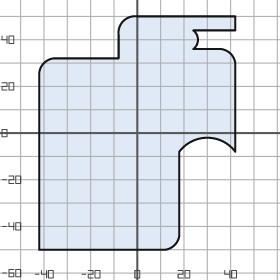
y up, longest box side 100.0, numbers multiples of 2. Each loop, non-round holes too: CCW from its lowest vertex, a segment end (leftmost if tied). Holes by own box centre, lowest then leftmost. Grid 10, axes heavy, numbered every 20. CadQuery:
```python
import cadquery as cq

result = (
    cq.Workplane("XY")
    .moveTo(-42.0, -50.0)
    .lineTo(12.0, -50.0)
    .threePointArc((16.0, -48.0), (18.0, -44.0))
    .lineTo(18.0, -8.0)
    .threePointArc((30.0, -2.0), (42.0, -8.0))
    .lineTo(42.0, 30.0)
    .threePointArc((40.0, 34.0), (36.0, 36.0))
    .lineTo(24.0, 36.0)
    .threePointArc((26.0, 40.0), (24.0, 44.0))
    .lineTo(42.0, 44.0)
    .lineTo(42.0, 50.0)
    .lineTo(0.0, 50.0)
    .threePointArc((-6.0, 48.0), (-8.0, 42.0))
    .lineTo(-8.0, 32.0)
    .lineTo(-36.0, 32.0)
    .threePointArc((-40.0, 30.0), (-42.0, 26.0))
    .close()
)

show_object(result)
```